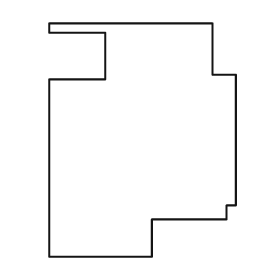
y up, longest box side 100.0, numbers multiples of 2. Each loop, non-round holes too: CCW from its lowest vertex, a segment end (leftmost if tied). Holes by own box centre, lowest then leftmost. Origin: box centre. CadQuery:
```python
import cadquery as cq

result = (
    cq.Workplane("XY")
    .moveTo(-40.0, -50.0)
    .lineTo(4.0, -50.0)
    .lineTo(4.0, -34.0)
    .lineTo(36.0, -34.0)
    .lineTo(36.0, -28.0)
    .lineTo(40.0, -28.0)
    .lineTo(40.0, 28.0)
    .lineTo(30.0, 28.0)
    .lineTo(30.0, 50.0)
    .lineTo(-40.0, 50.0)
    .lineTo(-40.0, 46.0)
    .lineTo(-16.0, 46.0)
    .lineTo(-16.0, 26.0)
    .lineTo(-40.0, 26.0)
    .close()
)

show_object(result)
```